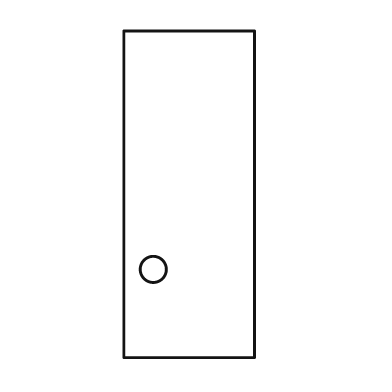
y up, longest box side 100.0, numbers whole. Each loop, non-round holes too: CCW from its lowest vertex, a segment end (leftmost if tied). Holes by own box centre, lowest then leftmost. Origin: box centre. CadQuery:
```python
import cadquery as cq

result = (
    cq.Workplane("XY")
    .moveTo(-20.0, -50.0)
    .lineTo(20.0, -50.0)
    .lineTo(20.0, 50.0)
    .lineTo(-20.0, 50.0)
    .close()
    .moveTo(-11.0, -23.0)
    .circle(4.0)
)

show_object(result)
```